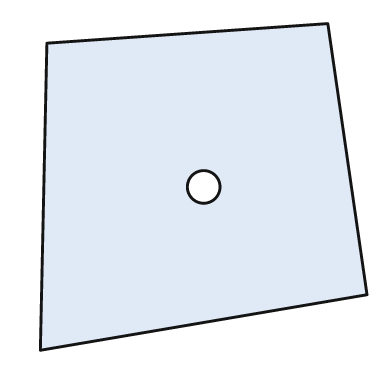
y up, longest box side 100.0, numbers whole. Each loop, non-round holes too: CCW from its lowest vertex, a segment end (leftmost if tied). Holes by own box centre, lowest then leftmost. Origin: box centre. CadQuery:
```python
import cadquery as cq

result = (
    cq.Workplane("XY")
    .moveTo(-50.0, -50.0)
    .lineTo(50.0, -33.0)
    .lineTo(38.0, 50.0)
    .lineTo(-48.0, 44.0)
    .close()
    .moveTo(0.0, 0.0)
    .circle(5.0)
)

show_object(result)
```